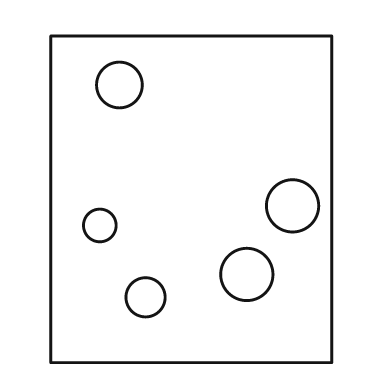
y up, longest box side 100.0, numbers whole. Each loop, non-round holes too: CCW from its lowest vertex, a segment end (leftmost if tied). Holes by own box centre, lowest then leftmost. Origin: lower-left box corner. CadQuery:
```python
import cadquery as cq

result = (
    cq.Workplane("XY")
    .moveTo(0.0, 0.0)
    .lineTo(86.0, 0.0)
    .lineTo(86.0, 100.0)
    .lineTo(0.0, 100.0)
    .close()
    .moveTo(29.0, 20.0)
    .circle(6.0)
    .moveTo(60.0, 27.0)
    .circle(8.0)
    .moveTo(15.0, 42.0)
    .circle(5.0)
    .moveTo(74.0, 48.0)
    .circle(8.0)
    .moveTo(21.0, 85.0)
    .circle(7.0)
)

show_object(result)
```